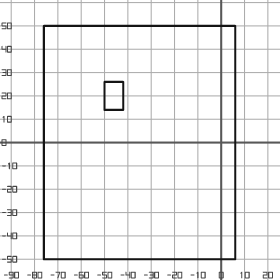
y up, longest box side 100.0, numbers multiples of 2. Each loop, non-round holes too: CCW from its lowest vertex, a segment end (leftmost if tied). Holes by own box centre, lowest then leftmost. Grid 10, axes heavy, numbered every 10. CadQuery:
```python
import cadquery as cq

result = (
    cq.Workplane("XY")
    .moveTo(-76.0, -50.0)
    .lineTo(6.0, -50.0)
    .lineTo(6.0, 50.0)
    .lineTo(-76.0, 50.0)
    .close()
    .moveTo(-50.0, 14.0)
    .lineTo(-42.0, 14.0)
    .lineTo(-42.0, 26.0)
    .lineTo(-50.0, 26.0)
    .close()
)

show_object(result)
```